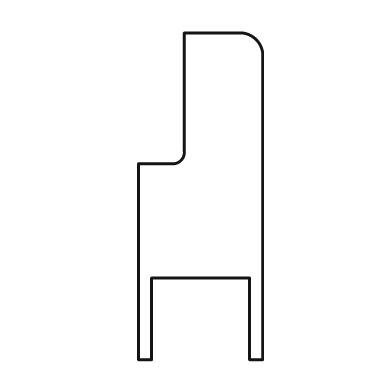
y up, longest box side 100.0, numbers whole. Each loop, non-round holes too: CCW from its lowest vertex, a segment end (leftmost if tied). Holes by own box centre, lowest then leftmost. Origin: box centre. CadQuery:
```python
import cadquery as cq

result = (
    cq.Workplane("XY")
    .moveTo(-19.0, -50.0)
    .lineTo(-15.0, -50.0)
    .lineTo(-15.0, -25.0)
    .lineTo(15.0, -25.0)
    .lineTo(15.0, -50.0)
    .lineTo(19.0, -50.0)
    .lineTo(19.0, 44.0)
    .threePointArc((17.0, 48.0), (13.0, 50.0))
    .lineTo(-5.0, 50.0)
    .lineTo(-5.0, 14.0)
    .threePointArc((-6.0, 11.0), (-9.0, 10.0))
    .lineTo(-19.0, 10.0)
    .close()
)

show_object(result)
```